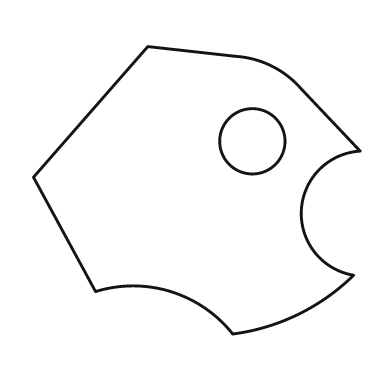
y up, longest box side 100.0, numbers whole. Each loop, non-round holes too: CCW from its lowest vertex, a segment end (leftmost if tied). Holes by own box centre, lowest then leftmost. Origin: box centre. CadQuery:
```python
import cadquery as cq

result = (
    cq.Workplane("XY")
    .moveTo(11.0, -44.0)
    .threePointArc((31.0, -38.0), (48.0, -26.0))
    .threePointArc((32.0, -6.0), (50.0, 12.0))
    .lineTo(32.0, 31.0)
    .threePointArc((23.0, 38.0), (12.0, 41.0))
    .lineTo(-15.0, 44.0)
    .lineTo(-50.0, 4.0)
    .lineTo(-31.0, -31.0)
    .threePointArc((-8.0, -31.0), (11.0, -44.0))
    .close()
    .moveTo(17.0, 15.0)
    .circle(10.0)
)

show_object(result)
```